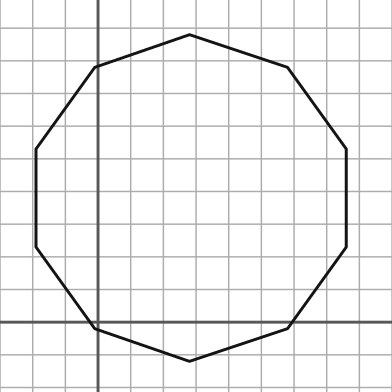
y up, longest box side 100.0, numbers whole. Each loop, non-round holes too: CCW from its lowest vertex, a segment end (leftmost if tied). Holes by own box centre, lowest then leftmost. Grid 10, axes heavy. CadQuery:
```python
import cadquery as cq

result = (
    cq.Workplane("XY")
    .moveTo(28.0, -12.0)
    .lineTo(58.0, -2.0)
    .lineTo(76.0, 23.0)
    .lineTo(76.0, 53.0)
    .lineTo(58.0, 78.0)
    .lineTo(28.0, 88.0)
    .lineTo(-1.0, 78.0)
    .lineTo(-19.0, 53.0)
    .lineTo(-19.0, 23.0)
    .lineTo(-1.0, -2.0)
    .close()
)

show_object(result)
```